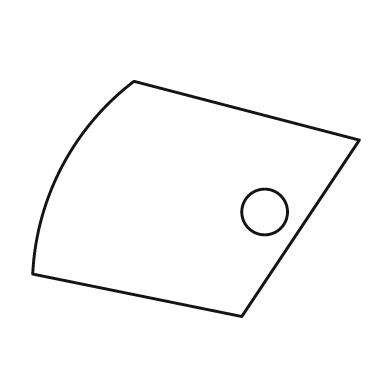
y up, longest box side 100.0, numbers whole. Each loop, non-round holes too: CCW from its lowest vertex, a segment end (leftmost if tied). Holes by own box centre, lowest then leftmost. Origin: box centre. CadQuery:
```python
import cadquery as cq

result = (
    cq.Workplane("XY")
    .moveTo(14.0, -36.0)
    .lineTo(50.0, 18.0)
    .lineTo(-19.0, 36.0)
    .threePointArc((-41.0, 10.0), (-50.0, -23.0))
    .close()
    .moveTo(21.0, -4.0)
    .circle(7.0)
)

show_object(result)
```